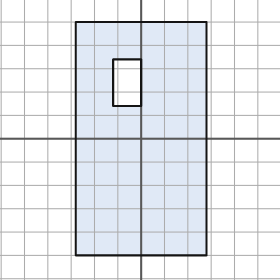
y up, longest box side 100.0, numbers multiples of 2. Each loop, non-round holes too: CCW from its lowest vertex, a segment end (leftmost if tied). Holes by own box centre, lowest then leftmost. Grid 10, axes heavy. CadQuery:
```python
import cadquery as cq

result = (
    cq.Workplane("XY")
    .moveTo(-28.0, -50.0)
    .lineTo(28.0, -50.0)
    .lineTo(28.0, 50.0)
    .lineTo(-28.0, 50.0)
    .close()
    .moveTo(-12.0, 14.0)
    .lineTo(0.0, 14.0)
    .lineTo(0.0, 34.0)
    .lineTo(-12.0, 34.0)
    .close()
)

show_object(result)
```